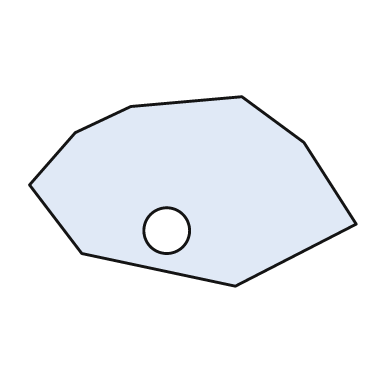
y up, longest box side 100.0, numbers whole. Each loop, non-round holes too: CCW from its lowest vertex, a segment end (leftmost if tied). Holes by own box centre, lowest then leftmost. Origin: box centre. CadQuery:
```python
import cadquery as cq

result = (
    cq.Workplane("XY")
    .moveTo(13.0, -29.0)
    .lineTo(50.0, -10.0)
    .lineTo(34.0, 15.0)
    .lineTo(15.0, 29.0)
    .lineTo(-19.0, 26.0)
    .lineTo(-36.0, 18.0)
    .lineTo(-50.0, 2.0)
    .lineTo(-34.0, -19.0)
    .close()
    .moveTo(-8.0, -12.0)
    .circle(7.0)
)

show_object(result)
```